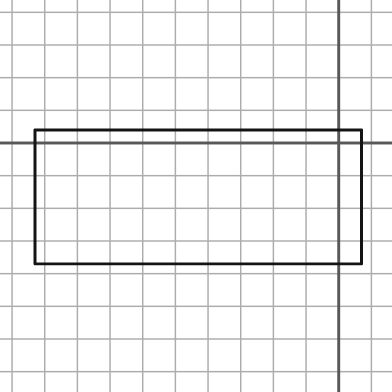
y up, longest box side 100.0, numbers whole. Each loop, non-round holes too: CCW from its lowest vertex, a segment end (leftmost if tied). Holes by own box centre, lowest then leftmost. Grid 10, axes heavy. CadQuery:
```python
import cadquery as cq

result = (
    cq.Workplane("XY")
    .moveTo(-93.0, -37.0)
    .lineTo(7.0, -37.0)
    .lineTo(7.0, 4.0)
    .lineTo(-93.0, 4.0)
    .close()
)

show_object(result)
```